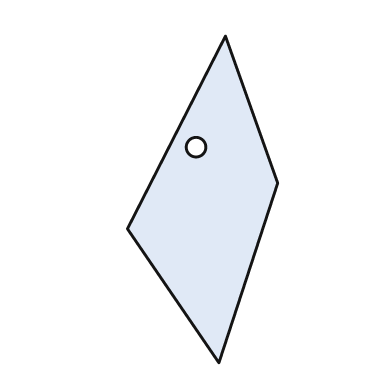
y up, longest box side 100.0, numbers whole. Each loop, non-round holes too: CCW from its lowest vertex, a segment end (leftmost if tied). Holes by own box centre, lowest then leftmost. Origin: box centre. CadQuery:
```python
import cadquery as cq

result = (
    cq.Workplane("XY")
    .moveTo(5.0, -50.0)
    .lineTo(23.0, 5.0)
    .lineTo(7.0, 50.0)
    .lineTo(-23.0, -9.0)
    .close()
    .moveTo(-2.0, 16.0)
    .circle(3.0)
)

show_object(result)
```